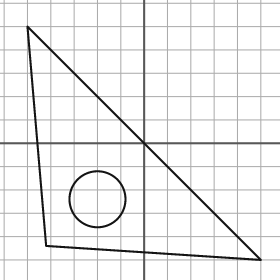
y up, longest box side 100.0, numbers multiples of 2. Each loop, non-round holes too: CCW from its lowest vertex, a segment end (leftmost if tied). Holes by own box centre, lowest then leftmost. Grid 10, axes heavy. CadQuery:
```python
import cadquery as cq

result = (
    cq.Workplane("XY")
    .moveTo(50.0, -50.0)
    .lineTo(-50.0, 50.0)
    .lineTo(-42.0, -44.0)
    .close()
    .moveTo(-20.0, -24.0)
    .circle(12.0)
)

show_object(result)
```